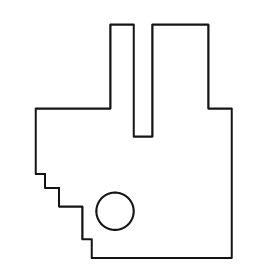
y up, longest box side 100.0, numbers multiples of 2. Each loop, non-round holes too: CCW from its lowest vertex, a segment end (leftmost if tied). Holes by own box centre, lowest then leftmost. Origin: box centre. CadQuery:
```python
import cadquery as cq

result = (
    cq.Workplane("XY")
    .moveTo(-18.0, -50.0)
    .lineTo(42.0, -50.0)
    .lineTo(42.0, 14.0)
    .lineTo(32.0, 14.0)
    .lineTo(32.0, 50.0)
    .lineTo(8.0, 50.0)
    .lineTo(8.0, 2.0)
    .lineTo(0.0, 2.0)
    .lineTo(0.0, 50.0)
    .lineTo(-10.0, 50.0)
    .lineTo(-10.0, 14.0)
    .lineTo(-42.0, 14.0)
    .lineTo(-42.0, -14.0)
    .lineTo(-38.0, -14.0)
    .lineTo(-38.0, -20.0)
    .lineTo(-32.0, -20.0)
    .lineTo(-32.0, -28.0)
    .lineTo(-22.0, -28.0)
    .lineTo(-22.0, -42.0)
    .lineTo(-18.0, -42.0)
    .close()
    .moveTo(-8.0, -30.0)
    .circle(8.0)
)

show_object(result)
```